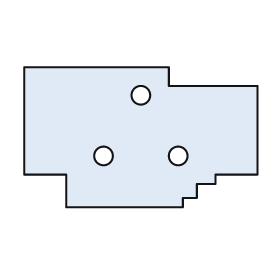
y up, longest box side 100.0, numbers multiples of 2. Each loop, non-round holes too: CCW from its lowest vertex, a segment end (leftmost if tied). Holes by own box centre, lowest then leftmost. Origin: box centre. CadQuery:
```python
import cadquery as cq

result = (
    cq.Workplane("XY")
    .moveTo(-32.0, -30.0)
    .lineTo(18.0, -30.0)
    .lineTo(18.0, -26.0)
    .lineTo(24.0, -26.0)
    .lineTo(24.0, -20.0)
    .lineTo(32.0, -20.0)
    .lineTo(32.0, -16.0)
    .lineTo(50.0, -16.0)
    .lineTo(50.0, 22.0)
    .lineTo(12.0, 22.0)
    .lineTo(12.0, 30.0)
    .lineTo(-50.0, 30.0)
    .lineTo(-50.0, -16.0)
    .lineTo(-32.0, -16.0)
    .close()
    .moveTo(-16.0, -8.0)
    .circle(4.0)
    .moveTo(16.0, -8.0)
    .circle(4.0)
    .moveTo(0.0, 18.0)
    .circle(4.0)
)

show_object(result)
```